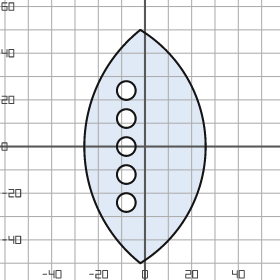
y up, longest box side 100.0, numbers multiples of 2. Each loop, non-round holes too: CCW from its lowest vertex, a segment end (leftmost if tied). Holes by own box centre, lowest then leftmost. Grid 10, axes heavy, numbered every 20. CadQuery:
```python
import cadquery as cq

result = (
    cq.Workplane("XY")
    .moveTo(-2.0, -50.0)
    .threePointArc((26.0, 0.0), (-2.0, 50.0))
    .threePointArc((-26.0, 0.0), (-2.0, -50.0))
    .close()
    .moveTo(-8.0, -24.0)
    .circle(4.0)
    .moveTo(-8.0, -12.0)
    .circle(4.0)
    .moveTo(-8.0, 0.0)
    .circle(4.0)
    .moveTo(-8.0, 12.0)
    .circle(4.0)
    .moveTo(-8.0, 24.0)
    .circle(4.0)
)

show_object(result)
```